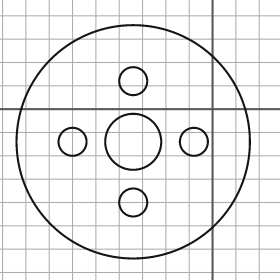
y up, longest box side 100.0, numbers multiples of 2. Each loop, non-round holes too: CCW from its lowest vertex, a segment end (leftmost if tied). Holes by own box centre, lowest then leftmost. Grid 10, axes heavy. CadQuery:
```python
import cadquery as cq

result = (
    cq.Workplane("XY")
    .moveTo(-34.0, -14.0)
    .circle(50.0)
    .moveTo(-34.0, -40.0)
    .circle(6.0)
    .moveTo(-60.0, -14.0)
    .circle(6.0)
    .moveTo(-34.0, -14.0)
    .circle(12.0)
    .moveTo(-8.0, -14.0)
    .circle(6.0)
    .moveTo(-34.0, 12.0)
    .circle(6.0)
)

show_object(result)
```